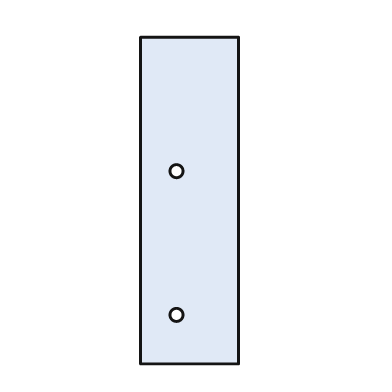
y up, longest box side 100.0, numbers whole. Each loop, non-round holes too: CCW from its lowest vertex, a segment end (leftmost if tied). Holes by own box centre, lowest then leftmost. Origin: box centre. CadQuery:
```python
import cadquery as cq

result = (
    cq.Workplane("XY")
    .moveTo(-15.0, -50.0)
    .lineTo(15.0, -50.0)
    .lineTo(15.0, 50.0)
    .lineTo(-15.0, 50.0)
    .close()
    .moveTo(-4.0, -35.0)
    .circle(2.0)
    .moveTo(-4.0, 9.0)
    .circle(2.0)
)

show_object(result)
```